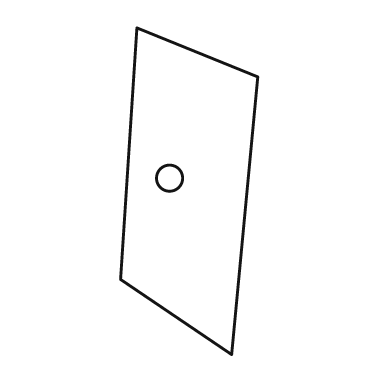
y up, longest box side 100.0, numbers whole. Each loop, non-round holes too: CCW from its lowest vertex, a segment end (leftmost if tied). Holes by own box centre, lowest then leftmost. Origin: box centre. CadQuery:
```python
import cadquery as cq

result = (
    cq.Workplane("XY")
    .moveTo(13.0, -50.0)
    .lineTo(21.0, 35.0)
    .lineTo(-16.0, 50.0)
    .lineTo(-21.0, -27.0)
    .close()
    .moveTo(-6.0, 4.0)
    .circle(4.0)
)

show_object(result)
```